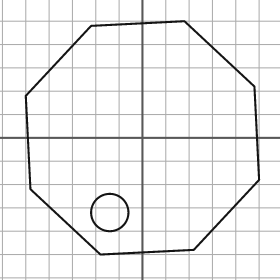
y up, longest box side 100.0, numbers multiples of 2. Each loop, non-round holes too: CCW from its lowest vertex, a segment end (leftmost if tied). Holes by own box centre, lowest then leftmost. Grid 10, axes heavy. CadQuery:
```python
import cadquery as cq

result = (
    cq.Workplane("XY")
    .moveTo(-18.0, -50.0)
    .lineTo(22.0, -48.0)
    .lineTo(50.0, -18.0)
    .lineTo(48.0, 22.0)
    .lineTo(18.0, 50.0)
    .lineTo(-22.0, 48.0)
    .lineTo(-50.0, 18.0)
    .lineTo(-48.0, -22.0)
    .close()
    .moveTo(-14.0, -32.0)
    .circle(8.0)
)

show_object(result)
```